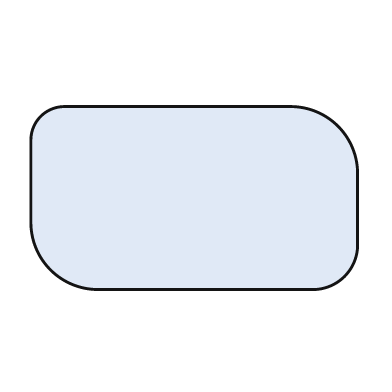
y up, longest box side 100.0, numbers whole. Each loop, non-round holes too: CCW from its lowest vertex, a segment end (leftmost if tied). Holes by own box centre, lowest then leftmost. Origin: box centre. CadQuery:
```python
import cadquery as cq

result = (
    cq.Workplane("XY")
    .moveTo(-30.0, -28.0)
    .lineTo(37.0, -28.0)
    .threePointArc((46.0, -24.0), (50.0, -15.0))
    .lineTo(50.0, 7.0)
    .threePointArc((44.0, 22.0), (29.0, 28.0))
    .lineTo(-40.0, 28.0)
    .threePointArc((-47.0, 25.0), (-50.0, 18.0))
    .lineTo(-50.0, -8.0)
    .threePointArc((-44.0, -22.0), (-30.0, -28.0))
    .close()
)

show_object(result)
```